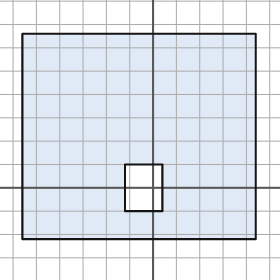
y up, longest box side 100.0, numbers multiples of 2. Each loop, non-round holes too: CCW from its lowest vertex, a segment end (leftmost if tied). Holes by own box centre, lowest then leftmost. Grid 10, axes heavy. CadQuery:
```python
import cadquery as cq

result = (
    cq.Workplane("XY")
    .moveTo(-56.0, -22.0)
    .lineTo(44.0, -22.0)
    .lineTo(44.0, 66.0)
    .lineTo(-56.0, 66.0)
    .close()
    .moveTo(-12.0, -10.0)
    .lineTo(4.0, -10.0)
    .lineTo(4.0, 10.0)
    .lineTo(-12.0, 10.0)
    .close()
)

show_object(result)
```